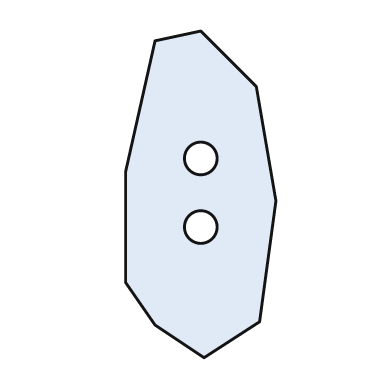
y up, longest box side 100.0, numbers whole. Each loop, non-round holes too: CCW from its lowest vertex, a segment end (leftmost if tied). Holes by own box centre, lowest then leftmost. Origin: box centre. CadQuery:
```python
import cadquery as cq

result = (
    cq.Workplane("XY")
    .moveTo(1.0, -50.0)
    .lineTo(18.0, -39.0)
    .lineTo(23.0, -2.0)
    .lineTo(17.0, 33.0)
    .lineTo(0.0, 50.0)
    .lineTo(-14.0, 47.0)
    .lineTo(-23.0, 7.0)
    .lineTo(-23.0, -27.0)
    .lineTo(-14.0, -40.0)
    .close()
    .moveTo(0.0, -10.0)
    .circle(5.0)
    .moveTo(0.0, 11.0)
    .circle(5.0)
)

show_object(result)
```